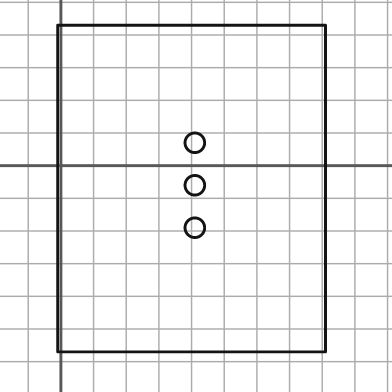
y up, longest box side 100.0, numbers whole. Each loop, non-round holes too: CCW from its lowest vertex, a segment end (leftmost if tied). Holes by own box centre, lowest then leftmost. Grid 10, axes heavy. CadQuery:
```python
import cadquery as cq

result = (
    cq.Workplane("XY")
    .moveTo(-1.0, -57.0)
    .lineTo(81.0, -57.0)
    .lineTo(81.0, 43.0)
    .lineTo(-1.0, 43.0)
    .close()
    .moveTo(41.0, -19.0)
    .circle(3.0)
    .moveTo(41.0, -6.0)
    .circle(3.0)
    .moveTo(41.0, 7.0)
    .circle(3.0)
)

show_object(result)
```